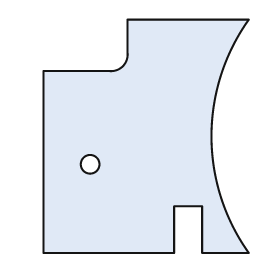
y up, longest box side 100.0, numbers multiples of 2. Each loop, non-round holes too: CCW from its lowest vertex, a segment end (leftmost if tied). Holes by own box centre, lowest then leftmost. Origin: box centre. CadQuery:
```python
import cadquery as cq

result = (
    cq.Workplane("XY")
    .moveTo(-44.0, -50.0)
    .lineTo(12.0, -50.0)
    .lineTo(12.0, -30.0)
    .lineTo(24.0, -30.0)
    .lineTo(24.0, -50.0)
    .lineTo(44.0, -50.0)
    .threePointArc((28.0, 0.0), (44.0, 50.0))
    .lineTo(-8.0, 50.0)
    .lineTo(-8.0, 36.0)
    .threePointArc((-10.0, 30.0), (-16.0, 28.0))
    .lineTo(-44.0, 28.0)
    .close()
    .moveTo(-24.0, -12.0)
    .circle(4.0)
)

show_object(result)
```